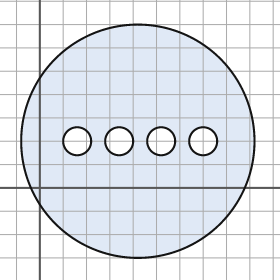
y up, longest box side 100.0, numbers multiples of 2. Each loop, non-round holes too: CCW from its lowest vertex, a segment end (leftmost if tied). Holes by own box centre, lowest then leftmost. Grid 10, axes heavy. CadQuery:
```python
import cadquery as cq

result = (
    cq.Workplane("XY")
    .moveTo(42.0, 20.0)
    .circle(50.0)
    .moveTo(16.0, 20.0)
    .circle(6.0)
    .moveTo(34.0, 20.0)
    .circle(6.0)
    .moveTo(52.0, 20.0)
    .circle(6.0)
    .moveTo(70.0, 20.0)
    .circle(6.0)
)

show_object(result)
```